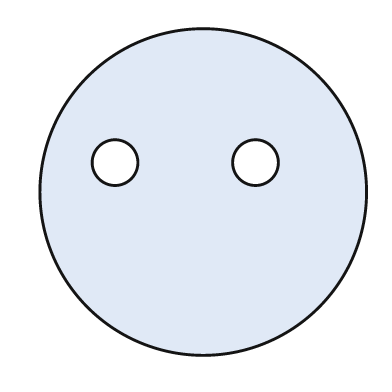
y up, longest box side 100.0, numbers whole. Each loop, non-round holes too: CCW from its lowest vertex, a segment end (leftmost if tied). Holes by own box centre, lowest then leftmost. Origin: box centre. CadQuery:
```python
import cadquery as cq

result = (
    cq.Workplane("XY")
    .moveTo(0.0, 0.0)
    .circle(50.0)
    .moveTo(-27.0, 9.0)
    .circle(7.0)
    .moveTo(16.0, 9.0)
    .circle(7.0)
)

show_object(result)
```